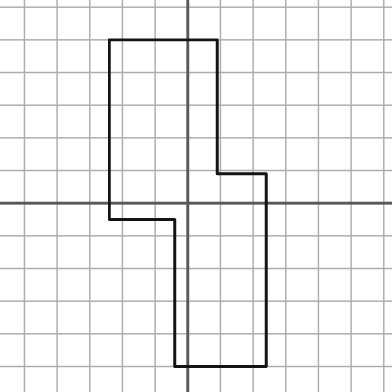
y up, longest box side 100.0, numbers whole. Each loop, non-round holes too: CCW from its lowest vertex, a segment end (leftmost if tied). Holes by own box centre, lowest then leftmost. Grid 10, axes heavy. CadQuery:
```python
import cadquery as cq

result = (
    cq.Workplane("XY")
    .moveTo(-4.0, -50.0)
    .lineTo(24.0, -50.0)
    .lineTo(24.0, 9.0)
    .lineTo(9.0, 9.0)
    .lineTo(9.0, 50.0)
    .lineTo(-24.0, 50.0)
    .lineTo(-24.0, -5.0)
    .lineTo(-4.0, -5.0)
    .close()
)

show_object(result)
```